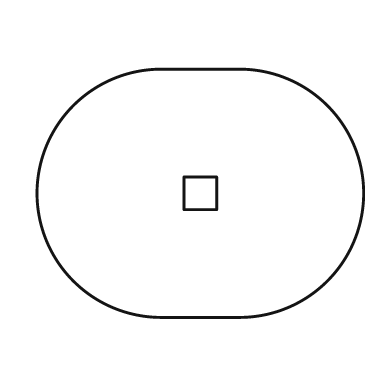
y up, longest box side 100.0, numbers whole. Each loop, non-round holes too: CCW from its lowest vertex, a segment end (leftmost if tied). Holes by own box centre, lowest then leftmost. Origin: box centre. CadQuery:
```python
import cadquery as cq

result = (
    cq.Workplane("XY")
    .moveTo(-12.0, -38.0)
    .lineTo(12.0, -38.0)
    .threePointArc((50.0, 0.0), (12.0, 38.0))
    .lineTo(-12.0, 38.0)
    .threePointArc((-50.0, 0.0), (-12.0, -38.0))
    .close()
    .moveTo(-5.0, -5.0)
    .lineTo(5.0, -5.0)
    .lineTo(5.0, 5.0)
    .lineTo(-5.0, 5.0)
    .close()
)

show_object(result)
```